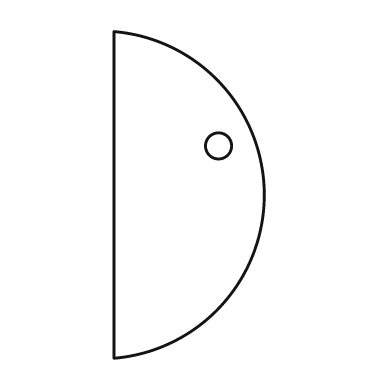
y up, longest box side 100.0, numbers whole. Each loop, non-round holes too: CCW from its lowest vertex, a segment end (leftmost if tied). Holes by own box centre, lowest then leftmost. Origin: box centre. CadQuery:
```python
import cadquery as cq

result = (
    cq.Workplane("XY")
    .moveTo(-23.0, -50.0)
    .threePointArc((23.0, 0.0), (-23.0, 50.0))
    .close()
    .moveTo(9.0, 15.0)
    .circle(4.0)
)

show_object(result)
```